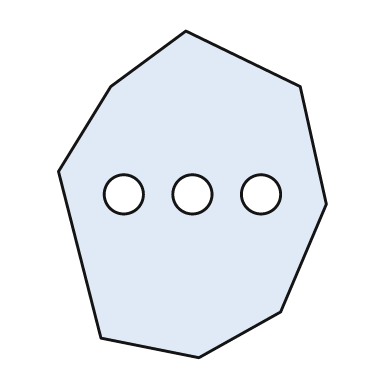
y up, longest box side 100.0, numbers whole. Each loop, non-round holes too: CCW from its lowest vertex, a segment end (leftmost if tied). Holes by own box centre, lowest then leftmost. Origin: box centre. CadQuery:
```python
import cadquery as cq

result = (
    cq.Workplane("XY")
    .moveTo(2.0, -50.0)
    .lineTo(27.0, -36.0)
    .lineTo(41.0, -3.0)
    .lineTo(33.0, 33.0)
    .lineTo(-2.0, 50.0)
    .lineTo(-25.0, 33.0)
    .lineTo(-41.0, 7.0)
    .lineTo(-28.0, -44.0)
    .close()
    .moveTo(-21.0, 0.0)
    .circle(6.0)
    .moveTo(0.0, 0.0)
    .circle(6.0)
    .moveTo(21.0, 0.0)
    .circle(6.0)
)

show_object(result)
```